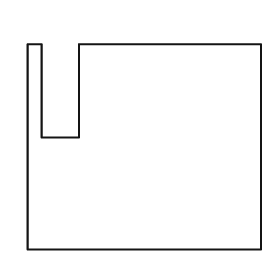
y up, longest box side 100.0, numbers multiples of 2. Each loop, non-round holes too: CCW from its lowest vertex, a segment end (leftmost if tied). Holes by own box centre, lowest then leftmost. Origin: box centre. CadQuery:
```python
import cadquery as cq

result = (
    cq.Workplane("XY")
    .moveTo(-50.0, -44.0)
    .lineTo(50.0, -44.0)
    .lineTo(50.0, 44.0)
    .lineTo(-28.0, 44.0)
    .lineTo(-28.0, 4.0)
    .lineTo(-44.0, 4.0)
    .lineTo(-44.0, 44.0)
    .lineTo(-50.0, 44.0)
    .close()
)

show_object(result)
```